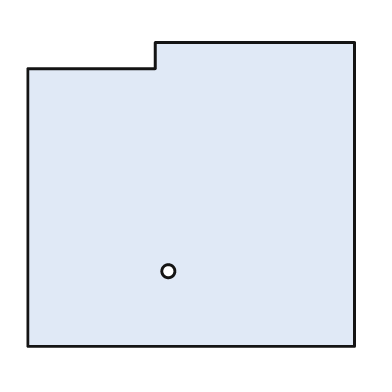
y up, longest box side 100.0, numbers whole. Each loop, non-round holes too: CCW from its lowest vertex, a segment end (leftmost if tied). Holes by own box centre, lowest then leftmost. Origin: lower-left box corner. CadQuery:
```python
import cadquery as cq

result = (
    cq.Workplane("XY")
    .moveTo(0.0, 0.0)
    .lineTo(100.0, 0.0)
    .lineTo(100.0, 93.0)
    .lineTo(39.0, 93.0)
    .lineTo(39.0, 85.0)
    .lineTo(0.0, 85.0)
    .close()
    .moveTo(43.0, 23.0)
    .circle(2.0)
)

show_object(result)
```